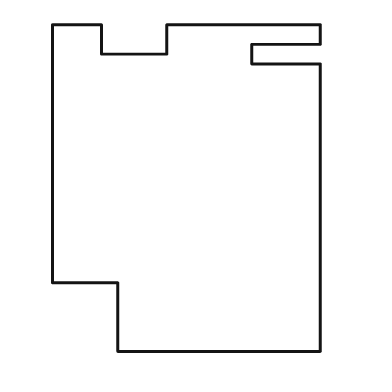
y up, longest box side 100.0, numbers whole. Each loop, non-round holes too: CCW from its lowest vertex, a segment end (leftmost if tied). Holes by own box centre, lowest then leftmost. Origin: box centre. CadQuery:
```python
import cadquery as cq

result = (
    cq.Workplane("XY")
    .moveTo(-21.0, -50.0)
    .lineTo(41.0, -50.0)
    .lineTo(41.0, 38.0)
    .lineTo(20.0, 38.0)
    .lineTo(20.0, 44.0)
    .lineTo(41.0, 44.0)
    .lineTo(41.0, 50.0)
    .lineTo(-6.0, 50.0)
    .lineTo(-6.0, 41.0)
    .lineTo(-26.0, 41.0)
    .lineTo(-26.0, 50.0)
    .lineTo(-41.0, 50.0)
    .lineTo(-41.0, -29.0)
    .lineTo(-21.0, -29.0)
    .close()
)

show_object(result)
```